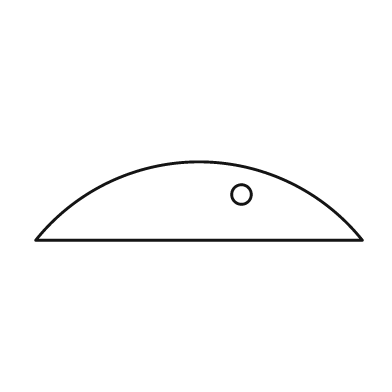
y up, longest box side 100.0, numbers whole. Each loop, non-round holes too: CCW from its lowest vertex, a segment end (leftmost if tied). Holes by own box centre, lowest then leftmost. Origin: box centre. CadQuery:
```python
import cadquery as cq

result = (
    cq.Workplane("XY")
    .moveTo(-50.0, -12.0)
    .lineTo(50.0, -12.0)
    .threePointArc((0.0, 12.0), (-50.0, -12.0))
    .close()
    .moveTo(13.0, 2.0)
    .circle(3.0)
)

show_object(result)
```